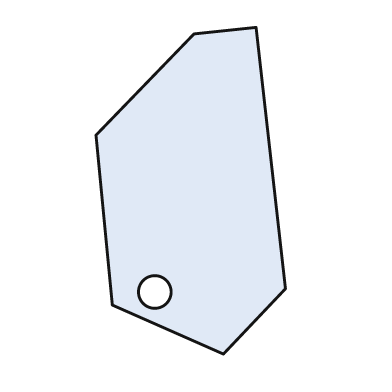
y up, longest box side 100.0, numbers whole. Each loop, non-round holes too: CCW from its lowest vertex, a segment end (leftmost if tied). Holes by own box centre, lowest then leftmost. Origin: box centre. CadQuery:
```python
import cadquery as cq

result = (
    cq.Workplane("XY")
    .moveTo(10.0, -50.0)
    .lineTo(29.0, -30.0)
    .lineTo(20.0, 50.0)
    .lineTo(1.0, 48.0)
    .lineTo(-29.0, 17.0)
    .lineTo(-24.0, -35.0)
    .close()
    .moveTo(-11.0, -31.0)
    .circle(5.0)
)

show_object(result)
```